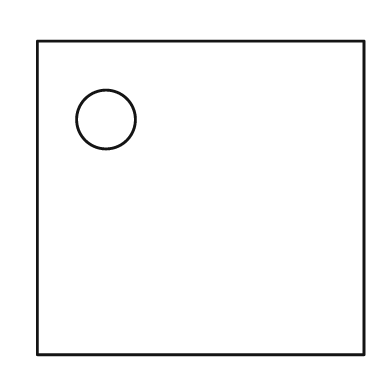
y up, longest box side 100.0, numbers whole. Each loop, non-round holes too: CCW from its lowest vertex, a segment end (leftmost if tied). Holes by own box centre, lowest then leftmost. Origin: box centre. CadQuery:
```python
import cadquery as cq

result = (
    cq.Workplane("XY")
    .moveTo(-50.0, -48.0)
    .lineTo(50.0, -48.0)
    .lineTo(50.0, 48.0)
    .lineTo(-50.0, 48.0)
    .close()
    .moveTo(-29.0, 24.0)
    .circle(9.0)
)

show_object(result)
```